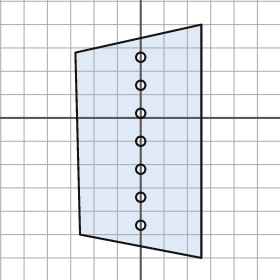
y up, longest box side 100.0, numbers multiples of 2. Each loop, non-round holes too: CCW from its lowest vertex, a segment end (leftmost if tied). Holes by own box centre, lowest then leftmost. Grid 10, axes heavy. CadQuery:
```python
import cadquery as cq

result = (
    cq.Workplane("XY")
    .moveTo(26.0, -60.0)
    .lineTo(26.0, 40.0)
    .lineTo(-28.0, 28.0)
    .lineTo(-26.0, -50.0)
    .close()
    .moveTo(0.0, -46.0)
    .circle(2.0)
    .moveTo(0.0, -34.0)
    .circle(2.0)
    .moveTo(0.0, -22.0)
    .circle(2.0)
    .moveTo(0.0, -10.0)
    .circle(2.0)
    .moveTo(0.0, 2.0)
    .circle(2.0)
    .moveTo(0.0, 14.0)
    .circle(2.0)
    .moveTo(0.0, 26.0)
    .circle(2.0)
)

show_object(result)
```